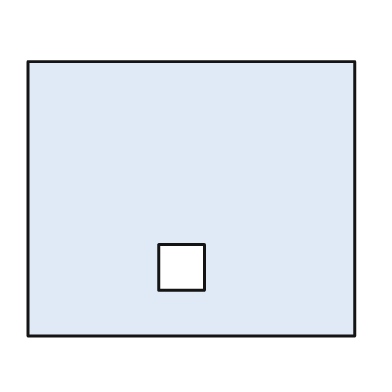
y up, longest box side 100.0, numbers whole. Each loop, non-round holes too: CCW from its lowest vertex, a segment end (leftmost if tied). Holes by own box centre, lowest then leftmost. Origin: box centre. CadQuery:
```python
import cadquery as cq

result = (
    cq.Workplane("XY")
    .moveTo(-50.0, -42.0)
    .lineTo(50.0, -42.0)
    .lineTo(50.0, 42.0)
    .lineTo(-50.0, 42.0)
    .close()
    .moveTo(-10.0, -28.0)
    .lineTo(4.0, -28.0)
    .lineTo(4.0, -14.0)
    .lineTo(-10.0, -14.0)
    .close()
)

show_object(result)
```